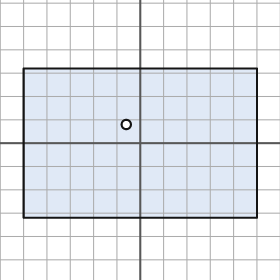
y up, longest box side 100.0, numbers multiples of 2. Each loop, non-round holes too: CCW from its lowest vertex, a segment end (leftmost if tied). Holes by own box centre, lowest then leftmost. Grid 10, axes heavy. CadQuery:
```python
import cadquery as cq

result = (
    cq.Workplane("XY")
    .moveTo(-50.0, -32.0)
    .lineTo(50.0, -32.0)
    .lineTo(50.0, 32.0)
    .lineTo(-50.0, 32.0)
    .close()
    .moveTo(-6.0, 8.0)
    .circle(2.0)
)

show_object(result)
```